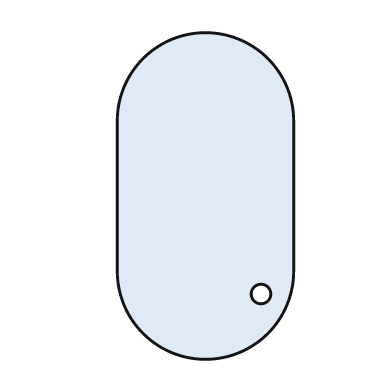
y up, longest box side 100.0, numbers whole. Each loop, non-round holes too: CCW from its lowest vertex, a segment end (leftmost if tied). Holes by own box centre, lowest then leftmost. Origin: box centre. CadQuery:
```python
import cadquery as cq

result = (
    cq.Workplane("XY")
    .moveTo(-27.0, -23.0)
    .threePointArc((0.0, -50.0), (27.0, -23.0))
    .lineTo(27.0, 23.0)
    .threePointArc((0.0, 50.0), (-27.0, 23.0))
    .close()
    .moveTo(17.0, -30.0)
    .circle(3.0)
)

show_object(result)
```